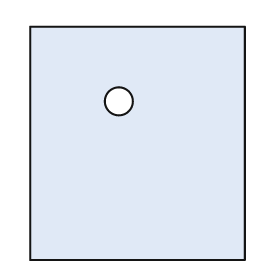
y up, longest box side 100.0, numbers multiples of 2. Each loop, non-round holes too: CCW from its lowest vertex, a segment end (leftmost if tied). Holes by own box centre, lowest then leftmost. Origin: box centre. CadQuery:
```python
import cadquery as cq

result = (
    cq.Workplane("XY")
    .moveTo(-46.0, -50.0)
    .lineTo(46.0, -50.0)
    .lineTo(46.0, 50.0)
    .lineTo(-46.0, 50.0)
    .close()
    .moveTo(-8.0, 18.0)
    .circle(6.0)
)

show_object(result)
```